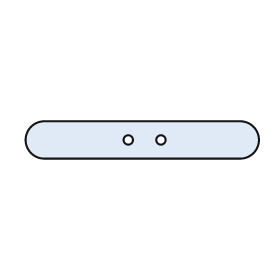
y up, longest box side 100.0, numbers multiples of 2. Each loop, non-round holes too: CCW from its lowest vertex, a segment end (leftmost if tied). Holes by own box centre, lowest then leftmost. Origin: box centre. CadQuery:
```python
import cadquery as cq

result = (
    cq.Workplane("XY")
    .moveTo(-42.0, -8.0)
    .lineTo(42.0, -8.0)
    .threePointArc((50.0, 0.0), (42.0, 8.0))
    .lineTo(-42.0, 8.0)
    .threePointArc((-50.0, 0.0), (-42.0, -8.0))
    .close()
    .moveTo(-6.0, 0.0)
    .circle(2.0)
    .moveTo(8.0, 0.0)
    .circle(2.0)
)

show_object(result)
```